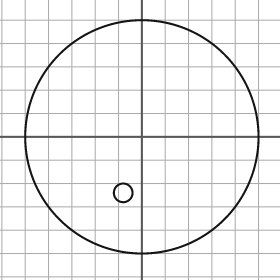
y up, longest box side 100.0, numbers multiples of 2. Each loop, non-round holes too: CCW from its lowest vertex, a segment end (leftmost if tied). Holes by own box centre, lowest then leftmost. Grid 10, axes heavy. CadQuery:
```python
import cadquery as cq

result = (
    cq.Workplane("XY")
    .moveTo(0.0, 0.0)
    .circle(50.0)
    .moveTo(-8.0, -24.0)
    .circle(4.0)
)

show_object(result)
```